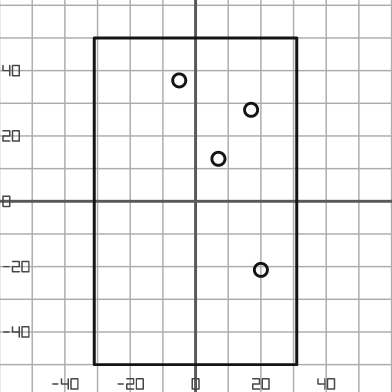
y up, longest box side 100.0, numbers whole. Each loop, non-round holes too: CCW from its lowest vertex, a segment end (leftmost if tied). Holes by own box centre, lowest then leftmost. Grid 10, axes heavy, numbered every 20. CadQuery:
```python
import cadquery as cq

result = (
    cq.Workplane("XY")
    .moveTo(-31.0, -50.0)
    .lineTo(31.0, -50.0)
    .lineTo(31.0, 50.0)
    .lineTo(-31.0, 50.0)
    .close()
    .moveTo(20.0, -21.0)
    .circle(2.0)
    .moveTo(7.0, 13.0)
    .circle(2.0)
    .moveTo(17.0, 28.0)
    .circle(2.0)
    .moveTo(-5.0, 37.0)
    .circle(2.0)
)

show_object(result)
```